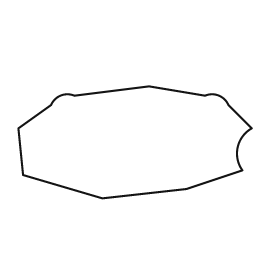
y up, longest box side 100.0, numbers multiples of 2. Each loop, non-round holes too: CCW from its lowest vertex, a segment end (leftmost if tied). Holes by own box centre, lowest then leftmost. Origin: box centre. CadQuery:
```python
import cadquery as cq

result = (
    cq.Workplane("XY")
    .moveTo(-14.0, -24.0)
    .lineTo(22.0, -20.0)
    .lineTo(46.0, -12.0)
    .threePointArc((44.0, -2.0), (50.0, 6.0))
    .lineTo(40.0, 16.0)
    .threePointArc((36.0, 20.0), (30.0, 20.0))
    .lineTo(6.0, 24.0)
    .lineTo(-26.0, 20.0)
    .threePointArc((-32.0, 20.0), (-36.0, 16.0))
    .lineTo(-50.0, 6.0)
    .lineTo(-48.0, -14.0)
    .close()
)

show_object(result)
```